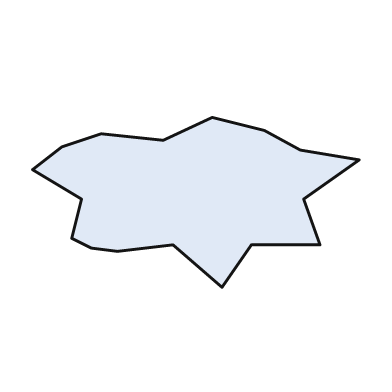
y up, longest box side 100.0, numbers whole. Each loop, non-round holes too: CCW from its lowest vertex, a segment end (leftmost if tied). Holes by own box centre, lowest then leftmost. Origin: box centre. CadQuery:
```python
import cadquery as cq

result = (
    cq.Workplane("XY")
    .moveTo(8.0, -26.0)
    .lineTo(17.0, -13.0)
    .lineTo(38.0, -13.0)
    .lineTo(33.0, 1.0)
    .lineTo(50.0, 13.0)
    .lineTo(32.0, 16.0)
    .lineTo(21.0, 22.0)
    .lineTo(5.0, 26.0)
    .lineTo(-10.0, 19.0)
    .lineTo(-29.0, 21.0)
    .lineTo(-41.0, 17.0)
    .lineTo(-50.0, 10.0)
    .lineTo(-35.0, 1.0)
    .lineTo(-38.0, -11.0)
    .lineTo(-32.0, -14.0)
    .lineTo(-24.0, -15.0)
    .lineTo(-7.0, -13.0)
    .close()
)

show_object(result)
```